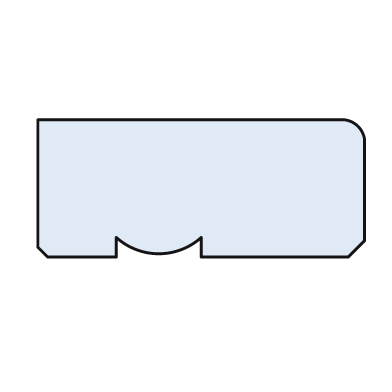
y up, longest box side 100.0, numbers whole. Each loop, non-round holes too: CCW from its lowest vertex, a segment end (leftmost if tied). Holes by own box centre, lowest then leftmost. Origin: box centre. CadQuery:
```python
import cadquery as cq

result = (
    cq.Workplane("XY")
    .moveTo(-47.0, -21.0)
    .lineTo(-26.0, -21.0)
    .lineTo(-26.0, -15.0)
    .threePointArc((-13.0, -20.0), (0.0, -15.0))
    .lineTo(0.0, -21.0)
    .lineTo(45.0, -21.0)
    .lineTo(50.0, -16.0)
    .lineTo(50.0, 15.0)
    .threePointArc((48.0, 19.0), (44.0, 21.0))
    .lineTo(-50.0, 21.0)
    .lineTo(-50.0, -18.0)
    .close()
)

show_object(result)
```